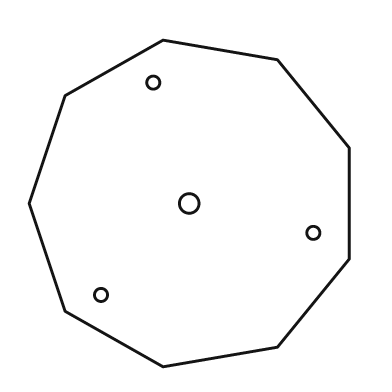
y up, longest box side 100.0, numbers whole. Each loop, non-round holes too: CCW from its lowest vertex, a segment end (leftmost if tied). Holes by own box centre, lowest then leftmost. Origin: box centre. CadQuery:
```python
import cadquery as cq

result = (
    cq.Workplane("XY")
    .moveTo(-8.0, -50.0)
    .lineTo(27.0, -44.0)
    .lineTo(49.0, -17.0)
    .lineTo(49.0, 17.0)
    .lineTo(27.0, 44.0)
    .lineTo(-8.0, 50.0)
    .lineTo(-38.0, 33.0)
    .lineTo(-49.0, 0.0)
    .lineTo(-38.0, -33.0)
    .close()
    .moveTo(-27.0, -28.0)
    .circle(2.0)
    .moveTo(38.0, -9.0)
    .circle(2.0)
    .moveTo(0.0, 0.0)
    .circle(3.0)
    .moveTo(-11.0, 37.0)
    .circle(2.0)
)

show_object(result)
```